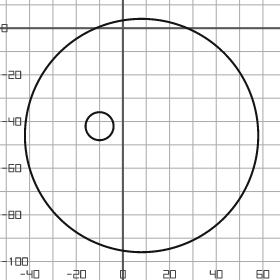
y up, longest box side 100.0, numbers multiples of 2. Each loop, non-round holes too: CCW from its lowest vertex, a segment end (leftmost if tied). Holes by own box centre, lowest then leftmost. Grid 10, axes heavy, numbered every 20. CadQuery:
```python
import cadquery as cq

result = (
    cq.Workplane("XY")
    .moveTo(8.0, -46.0)
    .circle(50.0)
    .moveTo(-10.0, -42.0)
    .circle(6.0)
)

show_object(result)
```